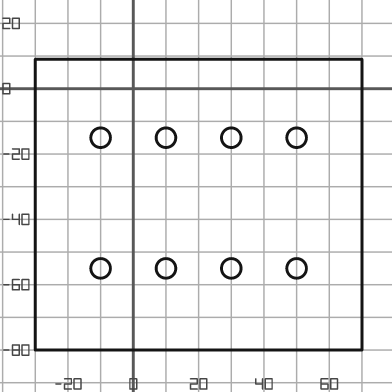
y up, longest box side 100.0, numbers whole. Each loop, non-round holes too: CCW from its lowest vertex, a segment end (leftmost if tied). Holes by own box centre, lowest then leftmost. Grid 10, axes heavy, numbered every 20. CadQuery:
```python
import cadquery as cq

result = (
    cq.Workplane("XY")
    .moveTo(-30.0, -80.0)
    .lineTo(70.0, -80.0)
    .lineTo(70.0, 9.0)
    .lineTo(-30.0, 9.0)
    .close()
    .moveTo(-10.0, -55.0)
    .circle(3.0)
    .moveTo(10.0, -55.0)
    .circle(3.0)
    .moveTo(30.0, -55.0)
    .circle(3.0)
    .moveTo(50.0, -55.0)
    .circle(3.0)
    .moveTo(-10.0, -15.0)
    .circle(3.0)
    .moveTo(10.0, -15.0)
    .circle(3.0)
    .moveTo(30.0, -15.0)
    .circle(3.0)
    .moveTo(50.0, -15.0)
    .circle(3.0)
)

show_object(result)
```